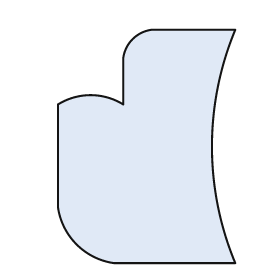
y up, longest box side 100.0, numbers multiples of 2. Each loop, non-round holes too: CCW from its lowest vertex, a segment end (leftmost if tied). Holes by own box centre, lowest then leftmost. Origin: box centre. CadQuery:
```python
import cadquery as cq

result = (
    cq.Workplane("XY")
    .moveTo(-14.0, -50.0)
    .lineTo(38.0, -50.0)
    .threePointArc((28.0, 0.0), (38.0, 50.0))
    .lineTo(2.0, 50.0)
    .threePointArc((-6.0, 46.0), (-10.0, 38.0))
    .lineTo(-10.0, 18.0)
    .threePointArc((-24.0, 22.0), (-38.0, 18.0))
    .lineTo(-38.0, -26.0)
    .threePointArc((-30.0, -42.0), (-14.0, -50.0))
    .close()
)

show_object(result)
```